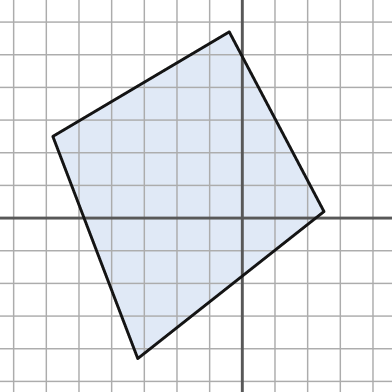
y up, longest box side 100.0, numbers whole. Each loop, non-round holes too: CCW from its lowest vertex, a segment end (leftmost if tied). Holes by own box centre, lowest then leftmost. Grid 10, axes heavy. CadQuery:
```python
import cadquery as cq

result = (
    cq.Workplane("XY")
    .moveTo(-32.0, -43.0)
    .lineTo(25.0, 2.0)
    .lineTo(-4.0, 57.0)
    .lineTo(-58.0, 25.0)
    .close()
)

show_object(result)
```